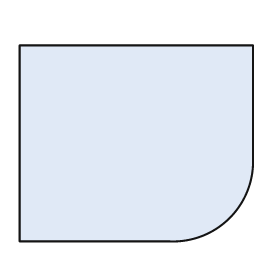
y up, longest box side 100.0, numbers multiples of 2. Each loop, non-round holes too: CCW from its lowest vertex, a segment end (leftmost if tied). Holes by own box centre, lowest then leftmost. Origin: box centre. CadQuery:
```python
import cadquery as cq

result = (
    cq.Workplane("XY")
    .moveTo(-50.0, -42.0)
    .lineTo(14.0, -42.0)
    .threePointArc((40.0, -32.0), (50.0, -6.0))
    .lineTo(50.0, 42.0)
    .lineTo(-50.0, 42.0)
    .close()
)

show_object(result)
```